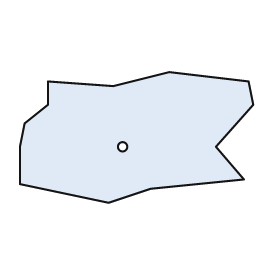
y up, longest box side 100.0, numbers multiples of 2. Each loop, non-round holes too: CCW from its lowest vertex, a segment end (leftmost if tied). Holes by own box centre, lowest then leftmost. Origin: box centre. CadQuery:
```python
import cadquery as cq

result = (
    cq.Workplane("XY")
    .moveTo(-12.0, -28.0)
    .lineTo(6.0, -22.0)
    .lineTo(46.0, -18.0)
    .lineTo(34.0, -4.0)
    .lineTo(50.0, 14.0)
    .lineTo(48.0, 24.0)
    .lineTo(14.0, 28.0)
    .lineTo(-10.0, 22.0)
    .lineTo(-38.0, 24.0)
    .lineTo(-38.0, 14.0)
    .lineTo(-48.0, 6.0)
    .lineTo(-50.0, -4.0)
    .lineTo(-50.0, -20.0)
    .close()
    .moveTo(-6.0, -4.0)
    .circle(2.0)
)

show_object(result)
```